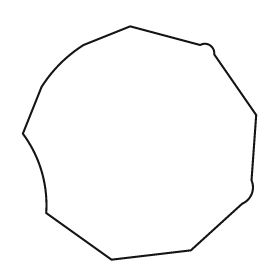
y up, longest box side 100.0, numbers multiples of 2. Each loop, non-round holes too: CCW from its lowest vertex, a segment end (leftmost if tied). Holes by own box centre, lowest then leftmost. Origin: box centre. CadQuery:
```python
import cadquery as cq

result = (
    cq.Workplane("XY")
    .moveTo(-12.0, -50.0)
    .lineTo(22.0, -46.0)
    .lineTo(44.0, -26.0)
    .threePointArc((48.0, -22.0), (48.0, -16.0))
    .lineTo(50.0, 12.0)
    .lineTo(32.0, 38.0)
    .threePointArc((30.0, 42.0), (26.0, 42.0))
    .lineTo(-4.0, 50.0)
    .lineTo(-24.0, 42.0)
    .threePointArc((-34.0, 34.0), (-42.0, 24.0))
    .lineTo(-50.0, 4.0)
    .threePointArc((-42.0, -12.0), (-40.0, -30.0))
    .close()
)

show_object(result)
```